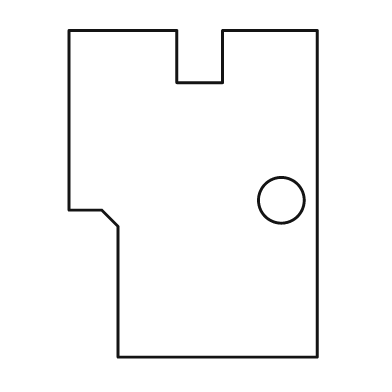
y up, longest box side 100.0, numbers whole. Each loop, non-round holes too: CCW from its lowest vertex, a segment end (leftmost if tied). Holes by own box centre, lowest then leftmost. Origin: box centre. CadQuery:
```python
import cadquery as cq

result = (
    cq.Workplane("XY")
    .moveTo(-23.0, -50.0)
    .lineTo(38.0, -50.0)
    .lineTo(38.0, 50.0)
    .lineTo(9.0, 50.0)
    .lineTo(9.0, 34.0)
    .lineTo(-5.0, 34.0)
    .lineTo(-5.0, 50.0)
    .lineTo(-38.0, 50.0)
    .lineTo(-38.0, -5.0)
    .lineTo(-28.0, -5.0)
    .lineTo(-23.0, -10.0)
    .close()
    .moveTo(27.0, -2.0)
    .circle(7.0)
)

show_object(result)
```